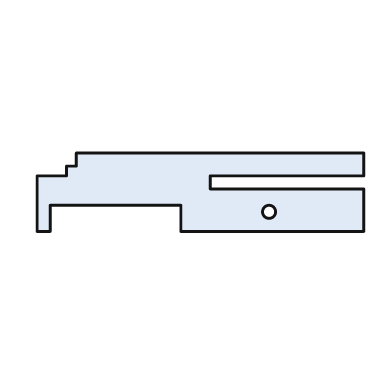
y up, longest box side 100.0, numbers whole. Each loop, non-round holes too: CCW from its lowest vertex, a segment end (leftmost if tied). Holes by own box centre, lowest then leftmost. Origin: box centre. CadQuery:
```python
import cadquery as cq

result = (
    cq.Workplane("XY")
    .moveTo(-50.0, -12.0)
    .lineTo(-46.0, -12.0)
    .lineTo(-46.0, -4.0)
    .lineTo(-6.0, -4.0)
    .lineTo(-6.0, -12.0)
    .lineTo(50.0, -12.0)
    .lineTo(50.0, 1.0)
    .lineTo(3.0, 1.0)
    .lineTo(3.0, 5.0)
    .lineTo(50.0, 5.0)
    .lineTo(50.0, 12.0)
    .lineTo(-38.0, 12.0)
    .lineTo(-38.0, 8.0)
    .lineTo(-41.0, 8.0)
    .lineTo(-41.0, 5.0)
    .lineTo(-50.0, 5.0)
    .close()
    .moveTo(21.0, -6.0)
    .circle(2.0)
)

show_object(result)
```